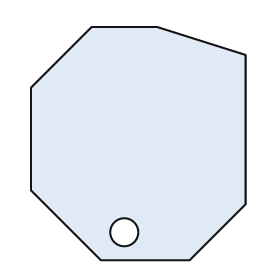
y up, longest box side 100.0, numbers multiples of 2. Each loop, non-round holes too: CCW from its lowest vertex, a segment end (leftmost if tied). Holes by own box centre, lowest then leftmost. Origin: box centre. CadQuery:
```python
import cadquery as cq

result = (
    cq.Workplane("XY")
    .moveTo(-16.0, -50.0)
    .lineTo(22.0, -50.0)
    .lineTo(46.0, -26.0)
    .lineTo(46.0, 38.0)
    .lineTo(8.0, 50.0)
    .lineTo(-20.0, 50.0)
    .lineTo(-46.0, 24.0)
    .lineTo(-46.0, -20.0)
    .close()
    .moveTo(-6.0, -38.0)
    .circle(6.0)
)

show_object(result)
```